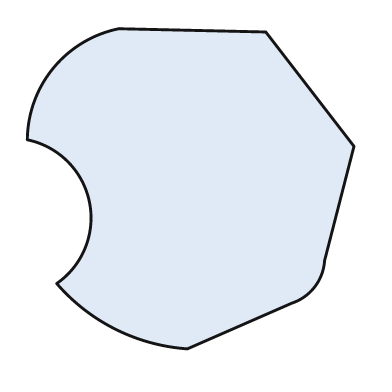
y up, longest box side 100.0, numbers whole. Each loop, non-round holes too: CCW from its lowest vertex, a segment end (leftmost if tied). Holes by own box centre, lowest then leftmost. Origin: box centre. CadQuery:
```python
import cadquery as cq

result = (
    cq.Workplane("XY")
    .moveTo(-1.0, -49.0)
    .lineTo(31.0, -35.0)
    .threePointArc((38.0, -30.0), (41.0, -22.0))
    .lineTo(50.0, 13.0)
    .lineTo(23.0, 48.0)
    .lineTo(-22.0, 49.0)
    .threePointArc((-42.0, 37.0), (-50.0, 15.0))
    .threePointArc((-31.0, -4.0), (-41.0, -29.0))
    .threePointArc((-23.0, -43.0), (-1.0, -49.0))
    .close()
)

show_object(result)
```